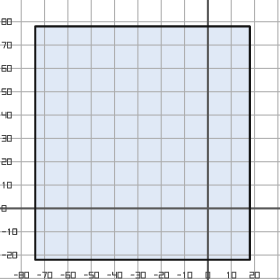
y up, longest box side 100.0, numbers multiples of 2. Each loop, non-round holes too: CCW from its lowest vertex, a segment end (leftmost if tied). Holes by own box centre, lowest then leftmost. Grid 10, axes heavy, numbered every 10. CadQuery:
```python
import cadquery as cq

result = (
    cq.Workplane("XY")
    .moveTo(-74.0, -22.0)
    .lineTo(18.0, -22.0)
    .lineTo(18.0, 78.0)
    .lineTo(-74.0, 78.0)
    .close()
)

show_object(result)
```